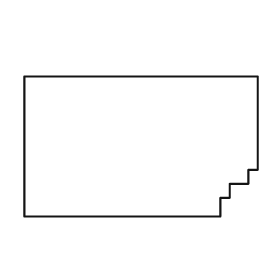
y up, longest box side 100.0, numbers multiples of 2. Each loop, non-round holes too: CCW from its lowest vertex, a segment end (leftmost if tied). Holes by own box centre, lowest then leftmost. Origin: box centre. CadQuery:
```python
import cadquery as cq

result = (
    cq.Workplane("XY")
    .moveTo(-50.0, -30.0)
    .lineTo(34.0, -30.0)
    .lineTo(34.0, -22.0)
    .lineTo(38.0, -22.0)
    .lineTo(38.0, -16.0)
    .lineTo(46.0, -16.0)
    .lineTo(46.0, -10.0)
    .lineTo(50.0, -10.0)
    .lineTo(50.0, 30.0)
    .lineTo(-50.0, 30.0)
    .close()
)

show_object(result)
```